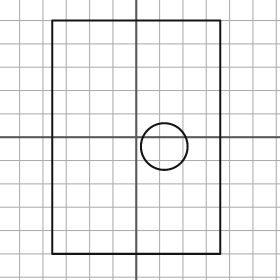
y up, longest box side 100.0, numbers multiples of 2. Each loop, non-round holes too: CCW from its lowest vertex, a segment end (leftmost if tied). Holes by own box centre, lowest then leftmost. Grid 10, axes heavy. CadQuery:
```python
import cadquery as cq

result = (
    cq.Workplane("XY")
    .moveTo(-36.0, -50.0)
    .lineTo(36.0, -50.0)
    .lineTo(36.0, 50.0)
    .lineTo(-36.0, 50.0)
    .close()
    .moveTo(12.0, -4.0)
    .circle(10.0)
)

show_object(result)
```